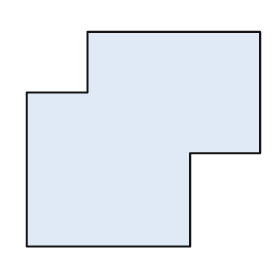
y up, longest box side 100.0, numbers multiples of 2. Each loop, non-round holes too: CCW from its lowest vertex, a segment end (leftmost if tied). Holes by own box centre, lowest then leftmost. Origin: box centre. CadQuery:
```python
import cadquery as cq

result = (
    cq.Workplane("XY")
    .moveTo(-50.0, -46.0)
    .lineTo(20.0, -46.0)
    .lineTo(20.0, -6.0)
    .lineTo(50.0, -6.0)
    .lineTo(50.0, 46.0)
    .lineTo(-24.0, 46.0)
    .lineTo(-24.0, 20.0)
    .lineTo(-50.0, 20.0)
    .close()
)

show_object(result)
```